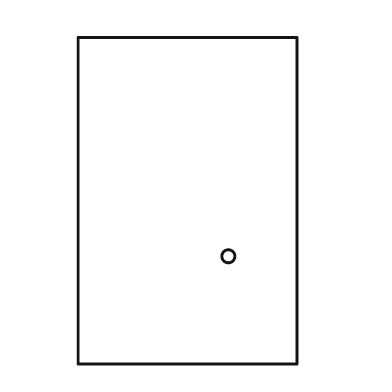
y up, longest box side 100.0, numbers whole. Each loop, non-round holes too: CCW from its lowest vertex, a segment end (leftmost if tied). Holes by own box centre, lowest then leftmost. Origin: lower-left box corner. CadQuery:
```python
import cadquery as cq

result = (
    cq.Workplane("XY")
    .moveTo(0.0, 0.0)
    .lineTo(67.0, 0.0)
    .lineTo(67.0, 100.0)
    .lineTo(0.0, 100.0)
    .close()
    .moveTo(46.0, 33.0)
    .circle(2.0)
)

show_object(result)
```